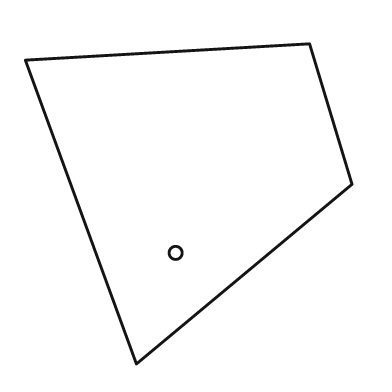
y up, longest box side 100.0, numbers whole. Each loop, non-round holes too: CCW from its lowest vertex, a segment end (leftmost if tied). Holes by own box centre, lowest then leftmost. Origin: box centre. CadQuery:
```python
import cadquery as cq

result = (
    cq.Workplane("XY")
    .moveTo(-16.0, -49.0)
    .lineTo(50.0, 6.0)
    .lineTo(37.0, 49.0)
    .lineTo(-50.0, 44.0)
    .close()
    .moveTo(-4.0, -15.0)
    .circle(2.0)
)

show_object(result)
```